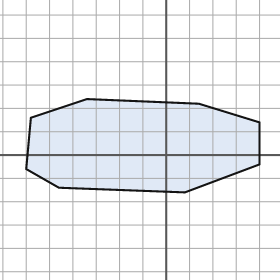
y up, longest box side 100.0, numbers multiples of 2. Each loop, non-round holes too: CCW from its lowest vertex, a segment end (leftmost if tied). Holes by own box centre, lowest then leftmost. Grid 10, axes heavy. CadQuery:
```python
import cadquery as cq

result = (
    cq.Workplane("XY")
    .moveTo(8.0, -16.0)
    .lineTo(40.0, -4.0)
    .lineTo(40.0, 14.0)
    .lineTo(14.0, 22.0)
    .lineTo(-34.0, 24.0)
    .lineTo(-58.0, 16.0)
    .lineTo(-60.0, -6.0)
    .lineTo(-46.0, -14.0)
    .close()
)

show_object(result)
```